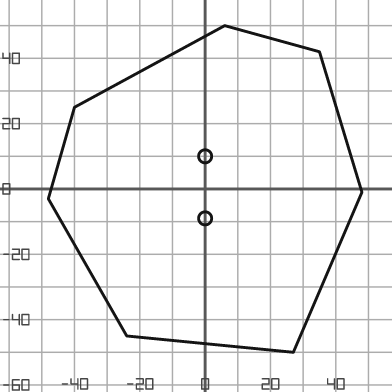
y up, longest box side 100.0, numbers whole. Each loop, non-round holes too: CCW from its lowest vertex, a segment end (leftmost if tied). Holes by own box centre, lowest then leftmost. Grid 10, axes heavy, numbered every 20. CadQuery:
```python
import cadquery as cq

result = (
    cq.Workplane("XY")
    .moveTo(27.0, -50.0)
    .lineTo(48.0, -1.0)
    .lineTo(35.0, 42.0)
    .lineTo(6.0, 50.0)
    .lineTo(-40.0, 25.0)
    .lineTo(-48.0, -3.0)
    .lineTo(-24.0, -45.0)
    .close()
    .moveTo(0.0, -9.0)
    .circle(2.0)
    .moveTo(0.0, 10.0)
    .circle(2.0)
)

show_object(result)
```